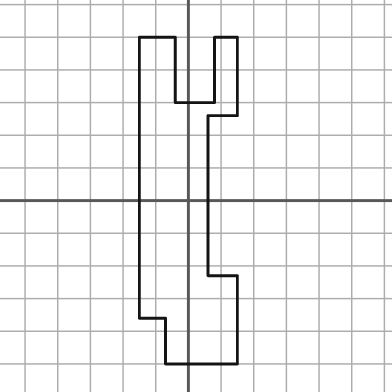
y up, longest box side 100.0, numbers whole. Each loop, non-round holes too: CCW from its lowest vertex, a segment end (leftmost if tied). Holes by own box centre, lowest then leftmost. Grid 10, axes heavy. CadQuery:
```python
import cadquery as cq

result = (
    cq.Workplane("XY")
    .moveTo(-7.0, -50.0)
    .lineTo(15.0, -50.0)
    .lineTo(15.0, -23.0)
    .lineTo(6.0, -23.0)
    .lineTo(6.0, 26.0)
    .lineTo(15.0, 26.0)
    .lineTo(15.0, 50.0)
    .lineTo(8.0, 50.0)
    .lineTo(8.0, 30.0)
    .lineTo(-4.0, 30.0)
    .lineTo(-4.0, 50.0)
    .lineTo(-15.0, 50.0)
    .lineTo(-15.0, -36.0)
    .lineTo(-7.0, -36.0)
    .close()
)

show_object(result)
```